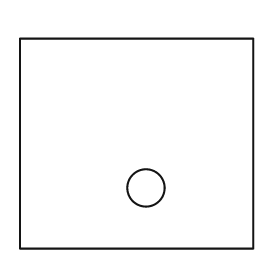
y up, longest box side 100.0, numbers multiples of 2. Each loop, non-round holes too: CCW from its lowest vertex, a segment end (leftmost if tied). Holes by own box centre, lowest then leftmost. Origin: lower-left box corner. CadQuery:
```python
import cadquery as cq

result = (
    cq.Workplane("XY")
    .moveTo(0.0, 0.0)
    .lineTo(100.0, 0.0)
    .lineTo(100.0, 90.0)
    .lineTo(0.0, 90.0)
    .close()
    .moveTo(54.0, 26.0)
    .circle(8.0)
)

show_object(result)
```